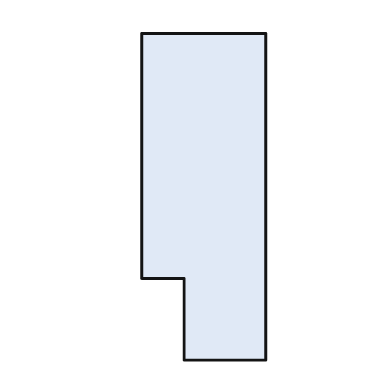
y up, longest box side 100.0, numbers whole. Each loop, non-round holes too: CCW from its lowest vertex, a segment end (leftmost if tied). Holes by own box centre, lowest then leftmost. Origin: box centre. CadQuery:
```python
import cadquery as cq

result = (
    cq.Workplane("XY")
    .moveTo(-6.0, -50.0)
    .lineTo(19.0, -50.0)
    .lineTo(19.0, 50.0)
    .lineTo(-19.0, 50.0)
    .lineTo(-19.0, -25.0)
    .lineTo(-6.0, -25.0)
    .close()
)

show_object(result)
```